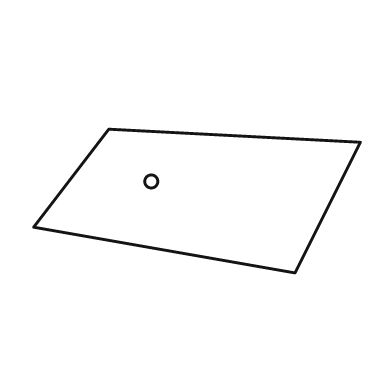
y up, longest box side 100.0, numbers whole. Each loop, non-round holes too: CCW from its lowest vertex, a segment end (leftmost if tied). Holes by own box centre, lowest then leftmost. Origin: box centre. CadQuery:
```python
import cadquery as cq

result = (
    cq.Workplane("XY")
    .moveTo(30.0, -22.0)
    .lineTo(50.0, 18.0)
    .lineTo(-27.0, 22.0)
    .lineTo(-50.0, -8.0)
    .close()
    .moveTo(-14.0, 6.0)
    .circle(2.0)
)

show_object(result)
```